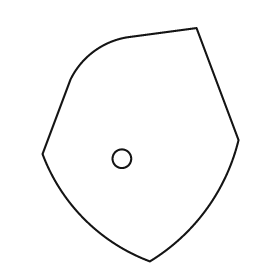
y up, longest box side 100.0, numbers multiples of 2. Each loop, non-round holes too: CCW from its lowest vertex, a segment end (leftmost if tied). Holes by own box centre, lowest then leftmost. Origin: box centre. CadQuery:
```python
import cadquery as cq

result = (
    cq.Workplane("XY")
    .moveTo(4.0, -50.0)
    .threePointArc((28.0, -28.0), (42.0, 2.0))
    .lineTo(24.0, 50.0)
    .lineTo(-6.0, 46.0)
    .threePointArc((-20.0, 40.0), (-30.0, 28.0))
    .lineTo(-42.0, -4.0)
    .threePointArc((-24.0, -32.0), (4.0, -50.0))
    .close()
    .moveTo(-8.0, -6.0)
    .circle(4.0)
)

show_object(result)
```